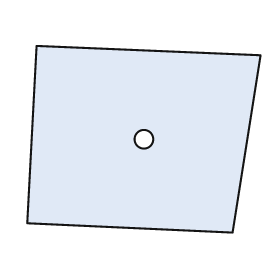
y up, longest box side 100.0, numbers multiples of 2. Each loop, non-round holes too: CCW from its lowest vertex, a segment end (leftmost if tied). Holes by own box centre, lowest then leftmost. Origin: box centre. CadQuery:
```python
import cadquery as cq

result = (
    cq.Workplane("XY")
    .moveTo(38.0, -40.0)
    .lineTo(50.0, 36.0)
    .lineTo(-46.0, 40.0)
    .lineTo(-50.0, -36.0)
    .close()
    .moveTo(0.0, 0.0)
    .circle(4.0)
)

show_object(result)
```